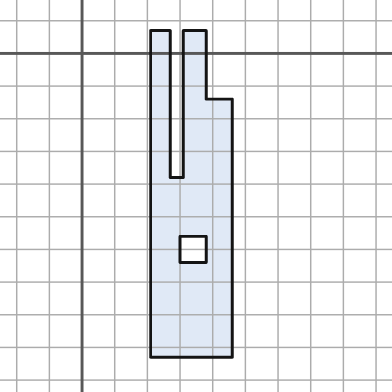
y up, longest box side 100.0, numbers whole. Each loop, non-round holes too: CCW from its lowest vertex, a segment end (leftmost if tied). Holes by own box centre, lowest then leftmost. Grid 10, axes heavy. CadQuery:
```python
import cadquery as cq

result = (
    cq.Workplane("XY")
    .moveTo(21.0, -93.0)
    .lineTo(46.0, -93.0)
    .lineTo(46.0, -14.0)
    .lineTo(38.0, -14.0)
    .lineTo(38.0, 7.0)
    .lineTo(31.0, 7.0)
    .lineTo(31.0, -38.0)
    .lineTo(27.0, -38.0)
    .lineTo(27.0, 7.0)
    .lineTo(21.0, 7.0)
    .close()
    .moveTo(30.0, -64.0)
    .lineTo(38.0, -64.0)
    .lineTo(38.0, -56.0)
    .lineTo(30.0, -56.0)
    .close()
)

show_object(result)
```